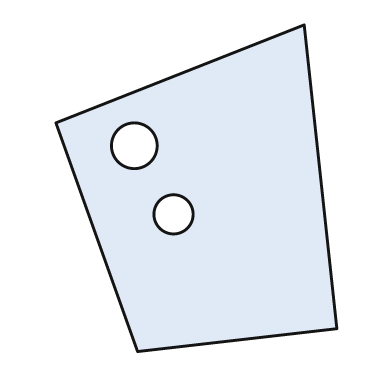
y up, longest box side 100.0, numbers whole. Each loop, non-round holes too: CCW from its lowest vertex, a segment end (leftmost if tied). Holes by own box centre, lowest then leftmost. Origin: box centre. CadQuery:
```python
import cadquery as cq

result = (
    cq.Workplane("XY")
    .moveTo(-18.0, -50.0)
    .lineTo(43.0, -43.0)
    .lineTo(33.0, 50.0)
    .lineTo(-43.0, 20.0)
    .close()
    .moveTo(-7.0, -8.0)
    .circle(6.0)
    .moveTo(-19.0, 13.0)
    .circle(7.0)
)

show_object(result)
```